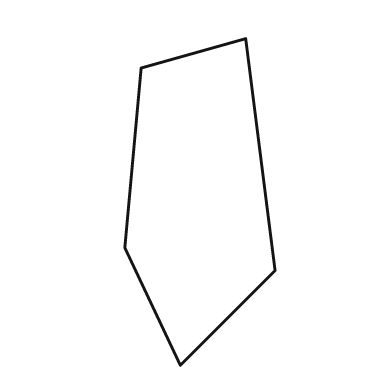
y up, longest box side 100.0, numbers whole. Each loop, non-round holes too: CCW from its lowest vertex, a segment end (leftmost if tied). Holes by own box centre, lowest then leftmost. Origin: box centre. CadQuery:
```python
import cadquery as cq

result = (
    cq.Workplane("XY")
    .moveTo(-6.0, -50.0)
    .lineTo(23.0, -21.0)
    .lineTo(14.0, 50.0)
    .lineTo(-18.0, 41.0)
    .lineTo(-23.0, -14.0)
    .close()
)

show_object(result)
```